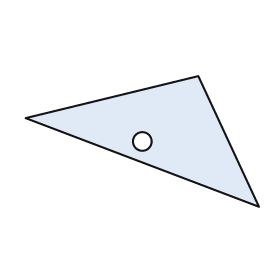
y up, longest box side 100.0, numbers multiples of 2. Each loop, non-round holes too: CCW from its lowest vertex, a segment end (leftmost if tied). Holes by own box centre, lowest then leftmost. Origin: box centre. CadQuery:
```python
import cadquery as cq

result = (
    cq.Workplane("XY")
    .moveTo(50.0, -28.0)
    .lineTo(24.0, 28.0)
    .lineTo(-50.0, 10.0)
    .close()
    .moveTo(0.0, 0.0)
    .circle(4.0)
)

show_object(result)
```